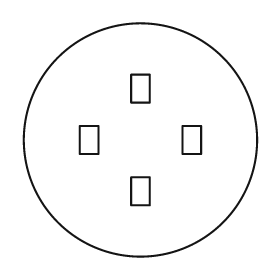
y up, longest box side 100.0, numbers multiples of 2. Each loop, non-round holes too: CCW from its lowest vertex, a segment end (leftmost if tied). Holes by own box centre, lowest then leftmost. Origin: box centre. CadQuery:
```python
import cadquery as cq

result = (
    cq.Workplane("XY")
    .moveTo(0.0, 0.0)
    .circle(50.0)
    .moveTo(-4.0, -28.0)
    .lineTo(4.0, -28.0)
    .lineTo(4.0, -16.0)
    .lineTo(-4.0, -16.0)
    .close()
    .moveTo(-26.0, -6.0)
    .lineTo(-18.0, -6.0)
    .lineTo(-18.0, 6.0)
    .lineTo(-26.0, 6.0)
    .close()
    .moveTo(18.0, -6.0)
    .lineTo(26.0, -6.0)
    .lineTo(26.0, 6.0)
    .lineTo(18.0, 6.0)
    .close()
    .moveTo(-4.0, 16.0)
    .lineTo(4.0, 16.0)
    .lineTo(4.0, 28.0)
    .lineTo(-4.0, 28.0)
    .close()
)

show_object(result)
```